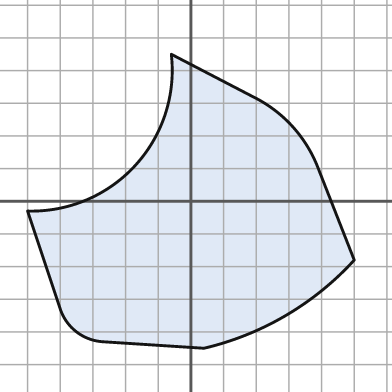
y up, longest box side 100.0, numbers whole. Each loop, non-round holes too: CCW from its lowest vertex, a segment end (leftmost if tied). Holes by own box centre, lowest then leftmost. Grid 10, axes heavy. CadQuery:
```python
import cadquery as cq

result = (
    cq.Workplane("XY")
    .moveTo(4.0, -45.0)
    .threePointArc((29.0, -35.0), (50.0, -18.0))
    .lineTo(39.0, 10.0)
    .threePointArc((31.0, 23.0), (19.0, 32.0))
    .lineTo(-6.0, 45.0)
    .threePointArc((-17.0, 11.0), (-50.0, -3.0))
    .lineTo(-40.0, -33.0)
    .threePointArc((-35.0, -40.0), (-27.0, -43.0))
    .close()
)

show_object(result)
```